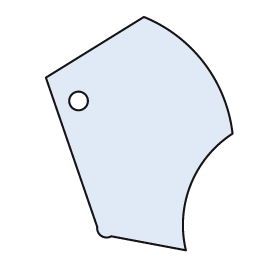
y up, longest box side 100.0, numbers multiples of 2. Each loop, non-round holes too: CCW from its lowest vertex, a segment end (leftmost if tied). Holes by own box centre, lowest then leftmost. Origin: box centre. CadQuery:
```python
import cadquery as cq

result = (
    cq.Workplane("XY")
    .moveTo(20.0, -50.0)
    .threePointArc((22.0, -22.0), (40.0, 0.0))
    .threePointArc((28.0, 30.0), (2.0, 50.0))
    .lineTo(-40.0, 24.0)
    .lineTo(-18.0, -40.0)
    .threePointArc((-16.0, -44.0), (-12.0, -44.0))
    .close()
    .moveTo(-26.0, 14.0)
    .circle(4.0)
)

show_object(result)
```